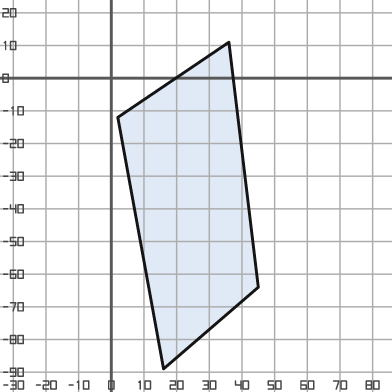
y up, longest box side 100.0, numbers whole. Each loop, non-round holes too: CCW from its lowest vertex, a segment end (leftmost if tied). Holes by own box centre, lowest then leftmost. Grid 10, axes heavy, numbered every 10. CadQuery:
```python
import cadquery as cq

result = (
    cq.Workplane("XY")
    .moveTo(16.0, -89.0)
    .lineTo(45.0, -64.0)
    .lineTo(36.0, 11.0)
    .lineTo(2.0, -12.0)
    .close()
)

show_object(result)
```